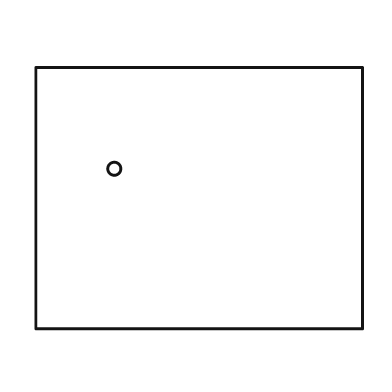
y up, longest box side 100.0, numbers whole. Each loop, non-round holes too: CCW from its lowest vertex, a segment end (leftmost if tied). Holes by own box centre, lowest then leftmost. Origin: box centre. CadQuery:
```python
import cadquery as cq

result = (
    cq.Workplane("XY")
    .moveTo(-50.0, -40.0)
    .lineTo(50.0, -40.0)
    .lineTo(50.0, 40.0)
    .lineTo(-50.0, 40.0)
    .close()
    .moveTo(-26.0, 9.0)
    .circle(2.0)
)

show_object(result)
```